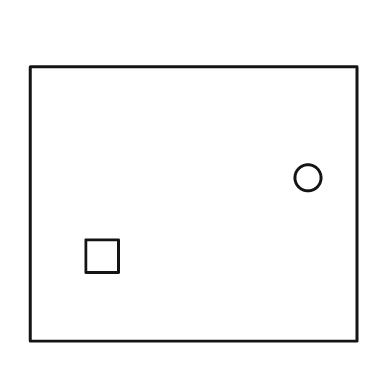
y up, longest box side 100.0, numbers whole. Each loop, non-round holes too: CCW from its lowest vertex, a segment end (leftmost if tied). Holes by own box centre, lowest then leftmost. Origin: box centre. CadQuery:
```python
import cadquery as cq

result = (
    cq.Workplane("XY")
    .moveTo(-50.0, -42.0)
    .lineTo(50.0, -42.0)
    .lineTo(50.0, 42.0)
    .lineTo(-50.0, 42.0)
    .close()
    .moveTo(-33.0, -21.0)
    .lineTo(-23.0, -21.0)
    .lineTo(-23.0, -11.0)
    .lineTo(-33.0, -11.0)
    .close()
    .moveTo(35.0, 8.0)
    .circle(4.0)
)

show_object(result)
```